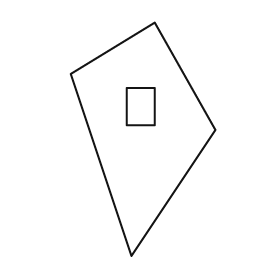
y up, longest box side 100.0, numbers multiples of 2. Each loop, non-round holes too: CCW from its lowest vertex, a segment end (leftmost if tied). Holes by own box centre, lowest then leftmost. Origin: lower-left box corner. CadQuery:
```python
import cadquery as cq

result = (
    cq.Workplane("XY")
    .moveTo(26.0, 0.0)
    .lineTo(62.0, 54.0)
    .lineTo(36.0, 100.0)
    .lineTo(0.0, 78.0)
    .close()
    .moveTo(24.0, 56.0)
    .lineTo(36.0, 56.0)
    .lineTo(36.0, 72.0)
    .lineTo(24.0, 72.0)
    .close()
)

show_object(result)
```